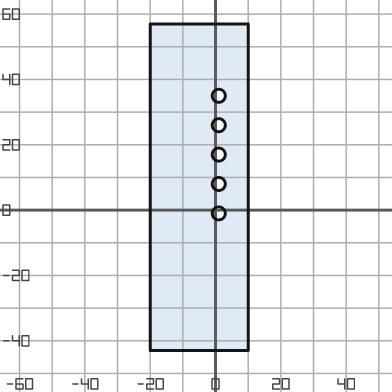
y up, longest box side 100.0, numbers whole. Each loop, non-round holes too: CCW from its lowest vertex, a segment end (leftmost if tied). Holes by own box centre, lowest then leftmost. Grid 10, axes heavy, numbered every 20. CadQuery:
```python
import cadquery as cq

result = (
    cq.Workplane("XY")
    .moveTo(-20.0, -43.0)
    .lineTo(10.0, -43.0)
    .lineTo(10.0, 57.0)
    .lineTo(-20.0, 57.0)
    .close()
    .moveTo(1.0, -1.0)
    .circle(2.0)
    .moveTo(1.0, 8.0)
    .circle(2.0)
    .moveTo(1.0, 17.0)
    .circle(2.0)
    .moveTo(1.0, 26.0)
    .circle(2.0)
    .moveTo(1.0, 35.0)
    .circle(2.0)
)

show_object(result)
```